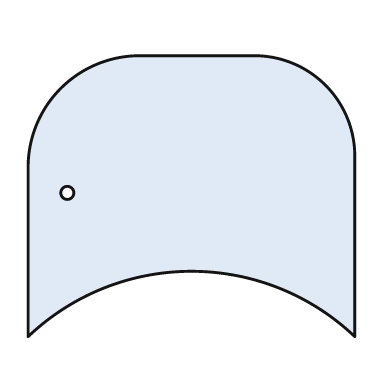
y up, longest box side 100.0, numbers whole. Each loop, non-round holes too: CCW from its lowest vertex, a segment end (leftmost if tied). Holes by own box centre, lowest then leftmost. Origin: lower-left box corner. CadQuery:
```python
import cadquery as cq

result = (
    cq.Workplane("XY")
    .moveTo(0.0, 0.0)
    .threePointArc((50.0, 20.0), (100.0, 0.0))
    .lineTo(100.0, 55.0)
    .threePointArc((91.0, 77.0), (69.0, 86.0))
    .lineTo(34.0, 86.0)
    .threePointArc((10.0, 76.0), (0.0, 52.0))
    .close()
    .moveTo(12.0, 44.0)
    .circle(2.0)
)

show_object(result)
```